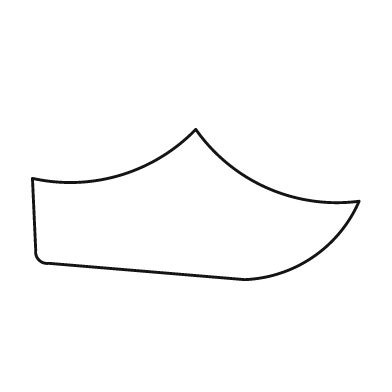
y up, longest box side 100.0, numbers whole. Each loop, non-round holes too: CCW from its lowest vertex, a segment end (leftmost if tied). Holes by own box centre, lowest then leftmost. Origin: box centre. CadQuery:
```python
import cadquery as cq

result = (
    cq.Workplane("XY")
    .moveTo(15.0, -23.0)
    .threePointArc((36.0, -16.0), (50.0, 1.0))
    .threePointArc((22.0, 5.0), (0.0, 23.0))
    .threePointArc((-23.0, 9.0), (-50.0, 8.0))
    .lineTo(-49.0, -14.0)
    .threePointArc((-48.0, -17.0), (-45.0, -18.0))
    .close()
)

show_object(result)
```